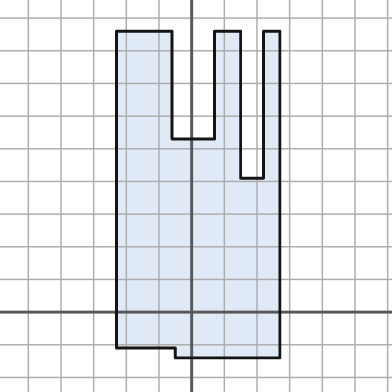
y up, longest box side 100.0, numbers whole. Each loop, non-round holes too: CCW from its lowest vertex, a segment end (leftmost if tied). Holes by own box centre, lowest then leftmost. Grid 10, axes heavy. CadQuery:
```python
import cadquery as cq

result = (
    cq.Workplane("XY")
    .moveTo(-5.0, -14.0)
    .lineTo(27.0, -14.0)
    .lineTo(27.0, 86.0)
    .lineTo(22.0, 86.0)
    .lineTo(22.0, 41.0)
    .lineTo(15.0, 41.0)
    .lineTo(15.0, 86.0)
    .lineTo(7.0, 86.0)
    .lineTo(7.0, 53.0)
    .lineTo(-6.0, 53.0)
    .lineTo(-6.0, 86.0)
    .lineTo(-23.0, 86.0)
    .lineTo(-23.0, -11.0)
    .lineTo(-5.0, -11.0)
    .close()
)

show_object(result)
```